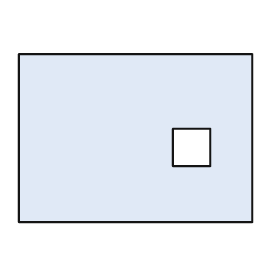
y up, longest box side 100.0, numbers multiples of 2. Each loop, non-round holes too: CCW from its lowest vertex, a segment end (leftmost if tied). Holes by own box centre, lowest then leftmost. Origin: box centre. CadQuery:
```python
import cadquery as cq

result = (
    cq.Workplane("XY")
    .moveTo(-50.0, -36.0)
    .lineTo(50.0, -36.0)
    .lineTo(50.0, 36.0)
    .lineTo(-50.0, 36.0)
    .close()
    .moveTo(16.0, -12.0)
    .lineTo(32.0, -12.0)
    .lineTo(32.0, 4.0)
    .lineTo(16.0, 4.0)
    .close()
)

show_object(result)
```